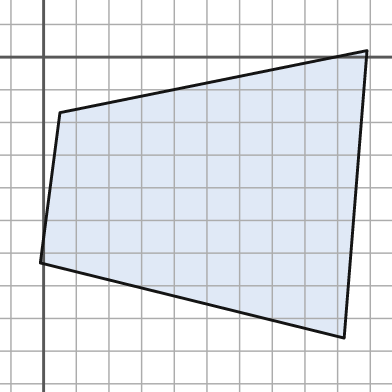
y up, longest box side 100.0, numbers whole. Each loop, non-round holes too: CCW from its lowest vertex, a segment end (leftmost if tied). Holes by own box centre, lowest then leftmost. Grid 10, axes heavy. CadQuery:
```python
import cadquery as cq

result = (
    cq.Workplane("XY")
    .moveTo(92.0, -86.0)
    .lineTo(99.0, 2.0)
    .lineTo(5.0, -17.0)
    .lineTo(-1.0, -63.0)
    .close()
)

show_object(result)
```